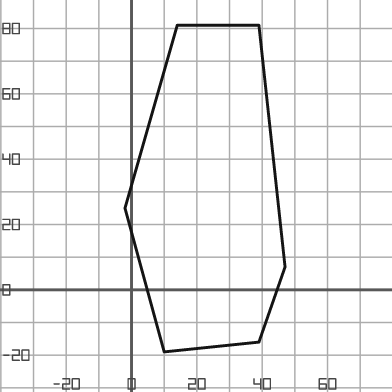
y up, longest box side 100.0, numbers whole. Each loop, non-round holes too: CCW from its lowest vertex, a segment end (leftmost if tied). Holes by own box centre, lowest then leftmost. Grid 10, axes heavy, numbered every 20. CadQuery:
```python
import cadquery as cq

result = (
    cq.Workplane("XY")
    .moveTo(10.0, -19.0)
    .lineTo(39.0, -16.0)
    .lineTo(47.0, 7.0)
    .lineTo(39.0, 81.0)
    .lineTo(14.0, 81.0)
    .lineTo(-2.0, 25.0)
    .close()
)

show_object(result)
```